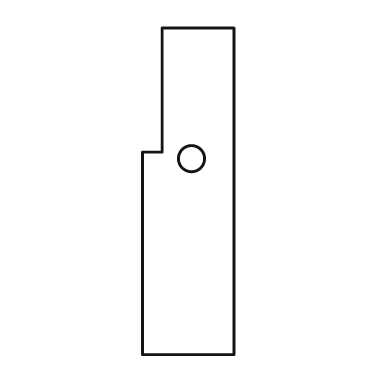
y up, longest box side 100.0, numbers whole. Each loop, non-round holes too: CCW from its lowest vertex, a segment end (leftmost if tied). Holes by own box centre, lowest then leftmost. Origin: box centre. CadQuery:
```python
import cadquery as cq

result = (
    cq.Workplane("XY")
    .moveTo(-14.0, -50.0)
    .lineTo(14.0, -50.0)
    .lineTo(14.0, 50.0)
    .lineTo(-8.0, 50.0)
    .lineTo(-8.0, 12.0)
    .lineTo(-14.0, 12.0)
    .close()
    .moveTo(1.0, 10.0)
    .circle(4.0)
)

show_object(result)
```